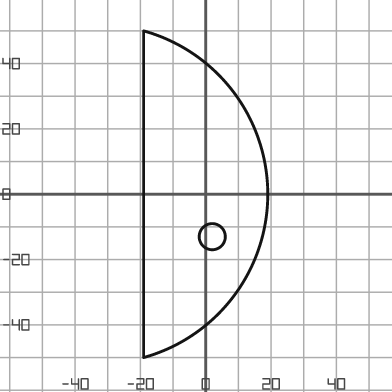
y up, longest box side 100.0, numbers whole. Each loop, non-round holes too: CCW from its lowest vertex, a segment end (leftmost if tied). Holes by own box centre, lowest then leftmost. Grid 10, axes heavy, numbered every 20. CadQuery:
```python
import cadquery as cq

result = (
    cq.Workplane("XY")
    .moveTo(-19.0, -50.0)
    .threePointArc((19.0, 0.0), (-19.0, 50.0))
    .close()
    .moveTo(2.0, -13.0)
    .circle(4.0)
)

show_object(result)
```